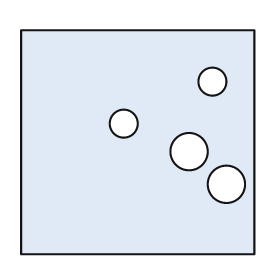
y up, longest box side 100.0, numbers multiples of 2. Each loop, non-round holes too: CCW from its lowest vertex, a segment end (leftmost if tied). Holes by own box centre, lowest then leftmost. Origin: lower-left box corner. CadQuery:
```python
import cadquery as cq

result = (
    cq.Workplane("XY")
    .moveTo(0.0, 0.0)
    .lineTo(100.0, 0.0)
    .lineTo(100.0, 96.0)
    .lineTo(0.0, 96.0)
    .close()
    .moveTo(88.0, 30.0)
    .circle(8.0)
    .moveTo(72.0, 44.0)
    .circle(8.0)
    .moveTo(44.0, 56.0)
    .circle(6.0)
    .moveTo(82.0, 74.0)
    .circle(6.0)
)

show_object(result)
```